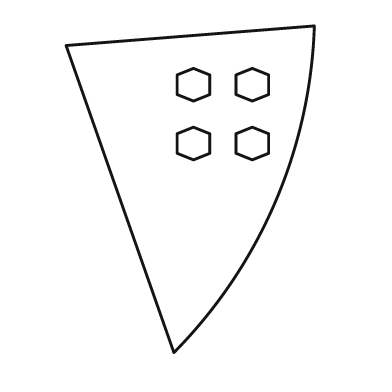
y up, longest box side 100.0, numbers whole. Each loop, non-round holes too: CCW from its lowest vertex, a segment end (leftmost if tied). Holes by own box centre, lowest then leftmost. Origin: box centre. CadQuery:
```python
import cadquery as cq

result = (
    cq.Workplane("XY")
    .moveTo(-5.0, -50.0)
    .threePointArc((26.0, -4.0), (38.0, 50.0))
    .lineTo(-38.0, 44.0)
    .close()
    .moveTo(1.0, 9.0)
    .lineTo(6.0, 11.0)
    .lineTo(6.0, 17.0)
    .lineTo(1.0, 19.0)
    .lineTo(-4.0, 17.0)
    .lineTo(-4.0, 11.0)
    .close()
    .moveTo(19.0, 9.0)
    .lineTo(24.0, 11.0)
    .lineTo(24.0, 17.0)
    .lineTo(19.0, 19.0)
    .lineTo(14.0, 17.0)
    .lineTo(14.0, 11.0)
    .close()
    .moveTo(1.0, 27.0)
    .lineTo(6.0, 29.0)
    .lineTo(6.0, 35.0)
    .lineTo(1.0, 37.0)
    .lineTo(-4.0, 35.0)
    .lineTo(-4.0, 29.0)
    .close()
    .moveTo(19.0, 27.0)
    .lineTo(24.0, 29.0)
    .lineTo(24.0, 35.0)
    .lineTo(19.0, 37.0)
    .lineTo(14.0, 35.0)
    .lineTo(14.0, 29.0)
    .close()
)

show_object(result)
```